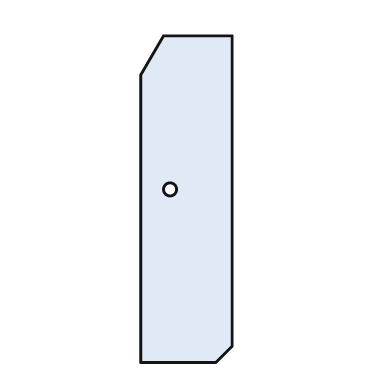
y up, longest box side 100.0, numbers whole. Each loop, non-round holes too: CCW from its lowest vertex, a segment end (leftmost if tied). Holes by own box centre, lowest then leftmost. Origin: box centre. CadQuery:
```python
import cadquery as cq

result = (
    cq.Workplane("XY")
    .moveTo(-14.0, -50.0)
    .lineTo(9.0, -50.0)
    .lineTo(14.0, -45.0)
    .lineTo(14.0, 50.0)
    .lineTo(-7.0, 50.0)
    .lineTo(-14.0, 38.0)
    .close()
    .moveTo(-5.0, 3.0)
    .circle(2.0)
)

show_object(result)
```